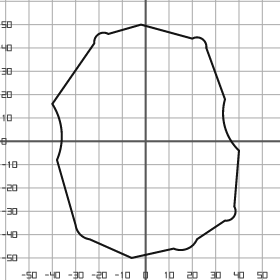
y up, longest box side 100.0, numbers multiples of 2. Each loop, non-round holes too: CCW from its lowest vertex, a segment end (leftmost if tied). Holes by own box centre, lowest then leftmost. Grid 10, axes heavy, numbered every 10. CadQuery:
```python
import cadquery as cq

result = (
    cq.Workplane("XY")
    .moveTo(-6.0, -50.0)
    .lineTo(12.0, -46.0)
    .threePointArc((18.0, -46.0), (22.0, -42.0))
    .lineTo(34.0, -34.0)
    .threePointArc((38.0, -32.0), (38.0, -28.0))
    .lineTo(40.0, -4.0)
    .threePointArc((34.0, 6.0), (34.0, 18.0))
    .lineTo(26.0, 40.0)
    .threePointArc((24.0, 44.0), (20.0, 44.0))
    .lineTo(-2.0, 50.0)
    .lineTo(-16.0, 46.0)
    .threePointArc((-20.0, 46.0), (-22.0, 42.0))
    .lineTo(-40.0, 16.0)
    .threePointArc((-36.0, 4.0), (-38.0, -8.0))
    .lineTo(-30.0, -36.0)
    .threePointArc((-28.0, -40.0), (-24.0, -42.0))
    .close()
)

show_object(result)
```